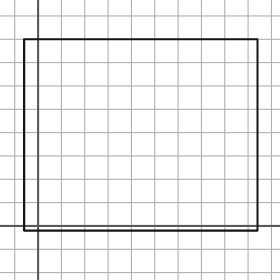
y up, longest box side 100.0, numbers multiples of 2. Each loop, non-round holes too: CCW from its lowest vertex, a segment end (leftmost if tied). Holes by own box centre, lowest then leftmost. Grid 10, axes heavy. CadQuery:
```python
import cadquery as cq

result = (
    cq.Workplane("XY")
    .moveTo(-6.0, -2.0)
    .lineTo(94.0, -2.0)
    .lineTo(94.0, 80.0)
    .lineTo(-6.0, 80.0)
    .close()
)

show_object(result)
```